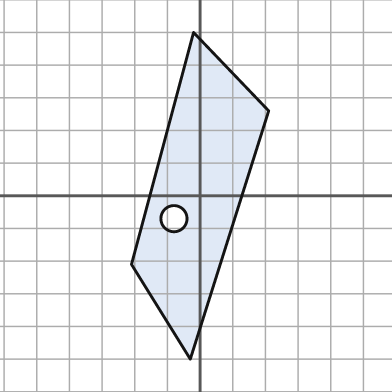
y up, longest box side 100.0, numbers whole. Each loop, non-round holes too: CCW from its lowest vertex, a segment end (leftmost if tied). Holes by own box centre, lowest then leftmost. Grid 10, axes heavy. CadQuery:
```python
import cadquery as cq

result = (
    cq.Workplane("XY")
    .moveTo(-3.0, -50.0)
    .lineTo(21.0, 26.0)
    .lineTo(-2.0, 50.0)
    .lineTo(-21.0, -21.0)
    .close()
    .moveTo(-8.0, -7.0)
    .circle(4.0)
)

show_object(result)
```